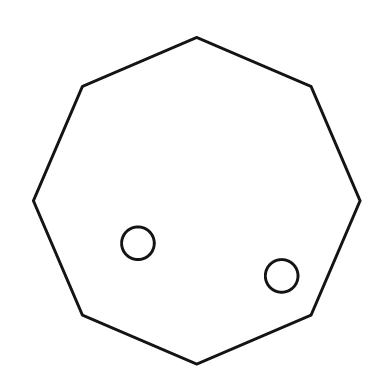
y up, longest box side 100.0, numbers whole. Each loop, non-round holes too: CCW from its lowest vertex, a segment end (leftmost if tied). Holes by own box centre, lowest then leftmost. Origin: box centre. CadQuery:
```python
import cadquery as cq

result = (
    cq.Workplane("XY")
    .moveTo(0.0, -50.0)
    .lineTo(35.0, -35.0)
    .lineTo(50.0, 0.0)
    .lineTo(35.0, 35.0)
    .lineTo(0.0, 50.0)
    .lineTo(-35.0, 35.0)
    .lineTo(-50.0, 0.0)
    .lineTo(-35.0, -35.0)
    .close()
    .moveTo(26.0, -23.0)
    .circle(5.0)
    .moveTo(-18.0, -13.0)
    .circle(5.0)
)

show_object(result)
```